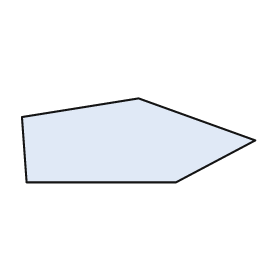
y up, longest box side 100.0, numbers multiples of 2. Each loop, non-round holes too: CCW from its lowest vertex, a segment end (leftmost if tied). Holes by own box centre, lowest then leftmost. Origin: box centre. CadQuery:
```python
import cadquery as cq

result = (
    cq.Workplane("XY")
    .moveTo(-48.0, -18.0)
    .lineTo(16.0, -18.0)
    .lineTo(50.0, 0.0)
    .lineTo(0.0, 18.0)
    .lineTo(-50.0, 10.0)
    .close()
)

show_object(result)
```